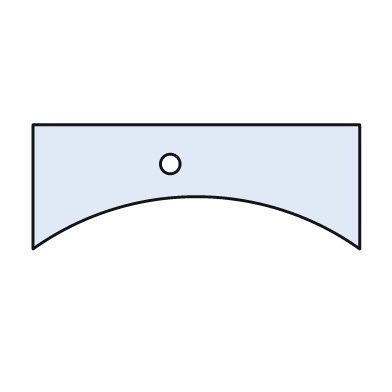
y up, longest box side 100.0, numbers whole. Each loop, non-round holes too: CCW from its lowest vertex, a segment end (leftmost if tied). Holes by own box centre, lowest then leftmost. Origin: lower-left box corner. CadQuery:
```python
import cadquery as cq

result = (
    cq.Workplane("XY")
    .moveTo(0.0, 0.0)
    .threePointArc((50.0, 16.0), (100.0, 0.0))
    .lineTo(100.0, 38.0)
    .lineTo(0.0, 38.0)
    .close()
    .moveTo(42.0, 26.0)
    .circle(3.0)
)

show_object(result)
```